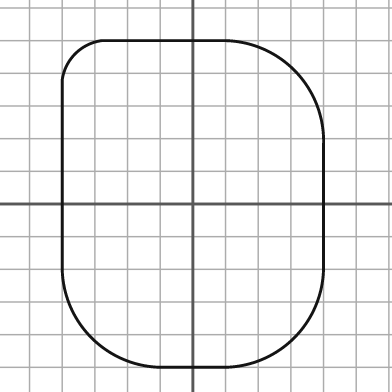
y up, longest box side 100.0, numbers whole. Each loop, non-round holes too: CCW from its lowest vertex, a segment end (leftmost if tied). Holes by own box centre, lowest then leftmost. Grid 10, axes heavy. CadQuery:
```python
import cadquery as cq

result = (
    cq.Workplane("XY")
    .moveTo(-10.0, -50.0)
    .lineTo(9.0, -50.0)
    .threePointArc((31.0, -41.0), (40.0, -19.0))
    .lineTo(40.0, 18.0)
    .threePointArc((31.0, 41.0), (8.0, 50.0))
    .lineTo(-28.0, 50.0)
    .threePointArc((-36.0, 46.0), (-40.0, 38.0))
    .lineTo(-40.0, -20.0)
    .threePointArc((-31.0, -41.0), (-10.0, -50.0))
    .close()
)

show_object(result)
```